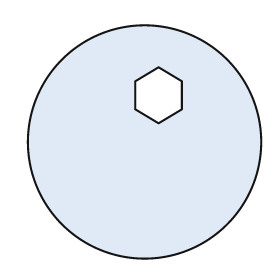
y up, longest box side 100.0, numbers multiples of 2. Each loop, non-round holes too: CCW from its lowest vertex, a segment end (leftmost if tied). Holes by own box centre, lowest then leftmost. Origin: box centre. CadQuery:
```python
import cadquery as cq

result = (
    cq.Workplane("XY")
    .moveTo(0.0, 0.0)
    .circle(50.0)
    .moveTo(6.0, 8.0)
    .lineTo(16.0, 14.0)
    .lineTo(16.0, 26.0)
    .lineTo(6.0, 32.0)
    .lineTo(-4.0, 26.0)
    .lineTo(-4.0, 14.0)
    .close()
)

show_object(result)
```